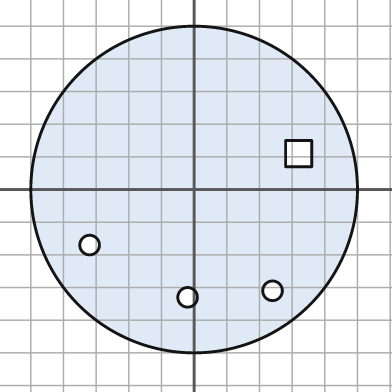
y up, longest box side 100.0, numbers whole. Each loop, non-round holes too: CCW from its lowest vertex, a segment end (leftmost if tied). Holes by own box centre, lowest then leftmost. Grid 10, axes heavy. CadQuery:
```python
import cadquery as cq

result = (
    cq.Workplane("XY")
    .moveTo(0.0, 0.0)
    .circle(50.0)
    .moveTo(-2.0, -33.0)
    .circle(3.0)
    .moveTo(24.0, -31.0)
    .circle(3.0)
    .moveTo(-32.0, -17.0)
    .circle(3.0)
    .moveTo(28.0, 7.0)
    .lineTo(36.0, 7.0)
    .lineTo(36.0, 15.0)
    .lineTo(28.0, 15.0)
    .close()
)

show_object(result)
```